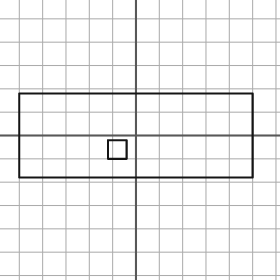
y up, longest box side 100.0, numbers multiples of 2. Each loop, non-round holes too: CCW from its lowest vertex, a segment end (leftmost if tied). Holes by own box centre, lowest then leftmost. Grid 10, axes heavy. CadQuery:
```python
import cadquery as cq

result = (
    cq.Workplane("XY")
    .moveTo(-50.0, -18.0)
    .lineTo(50.0, -18.0)
    .lineTo(50.0, 18.0)
    .lineTo(-50.0, 18.0)
    .close()
    .moveTo(-12.0, -10.0)
    .lineTo(-4.0, -10.0)
    .lineTo(-4.0, -2.0)
    .lineTo(-12.0, -2.0)
    .close()
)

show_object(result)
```